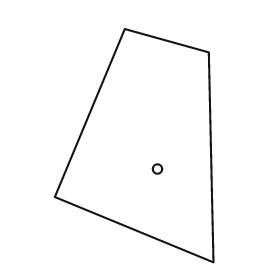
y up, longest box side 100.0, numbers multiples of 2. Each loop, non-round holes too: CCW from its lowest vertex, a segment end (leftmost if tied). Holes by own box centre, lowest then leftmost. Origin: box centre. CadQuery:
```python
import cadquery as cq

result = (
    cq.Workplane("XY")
    .moveTo(34.0, -50.0)
    .lineTo(32.0, 40.0)
    .lineTo(-4.0, 50.0)
    .lineTo(-34.0, -22.0)
    .close()
    .moveTo(10.0, -10.0)
    .circle(2.0)
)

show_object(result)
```